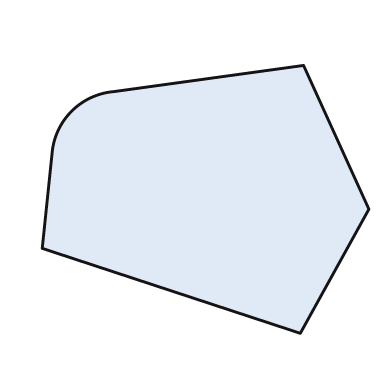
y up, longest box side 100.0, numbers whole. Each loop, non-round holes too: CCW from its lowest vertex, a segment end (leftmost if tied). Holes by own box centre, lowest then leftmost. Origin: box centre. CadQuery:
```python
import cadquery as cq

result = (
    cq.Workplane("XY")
    .moveTo(29.0, -41.0)
    .lineTo(50.0, -3.0)
    .lineTo(30.0, 41.0)
    .lineTo(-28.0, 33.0)
    .threePointArc((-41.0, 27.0), (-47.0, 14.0))
    .lineTo(-50.0, -15.0)
    .close()
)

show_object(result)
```